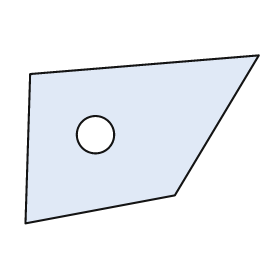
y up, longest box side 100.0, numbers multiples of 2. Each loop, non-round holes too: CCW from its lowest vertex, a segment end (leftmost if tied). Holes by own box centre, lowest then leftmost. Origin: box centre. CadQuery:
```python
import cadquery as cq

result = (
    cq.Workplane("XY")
    .moveTo(-50.0, -36.0)
    .lineTo(14.0, -24.0)
    .lineTo(50.0, 36.0)
    .lineTo(-48.0, 28.0)
    .close()
    .moveTo(-20.0, 2.0)
    .circle(8.0)
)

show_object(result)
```